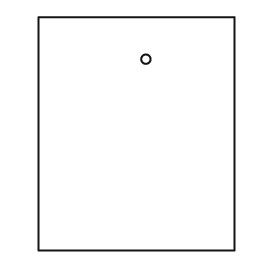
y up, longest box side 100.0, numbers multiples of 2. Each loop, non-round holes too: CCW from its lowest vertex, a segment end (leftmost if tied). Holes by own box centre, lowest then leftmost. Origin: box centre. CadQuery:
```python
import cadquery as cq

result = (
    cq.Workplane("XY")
    .moveTo(-42.0, -50.0)
    .lineTo(42.0, -50.0)
    .lineTo(42.0, 50.0)
    .lineTo(-42.0, 50.0)
    .close()
    .moveTo(4.0, 32.0)
    .circle(2.0)
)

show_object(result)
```